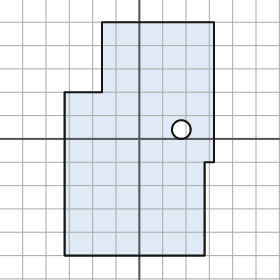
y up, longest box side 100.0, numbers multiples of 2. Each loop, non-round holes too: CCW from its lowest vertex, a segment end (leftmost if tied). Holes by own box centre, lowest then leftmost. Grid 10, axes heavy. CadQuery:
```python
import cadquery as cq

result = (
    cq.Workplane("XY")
    .moveTo(-32.0, -50.0)
    .lineTo(28.0, -50.0)
    .lineTo(28.0, -10.0)
    .lineTo(32.0, -10.0)
    .lineTo(32.0, 50.0)
    .lineTo(-16.0, 50.0)
    .lineTo(-16.0, 20.0)
    .lineTo(-32.0, 20.0)
    .close()
    .moveTo(18.0, 4.0)
    .circle(4.0)
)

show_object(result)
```